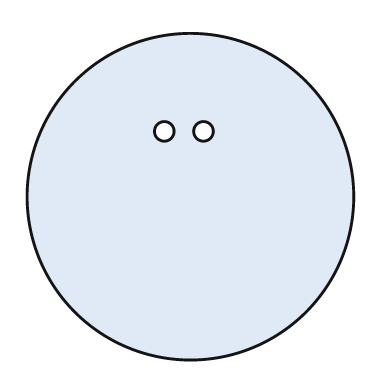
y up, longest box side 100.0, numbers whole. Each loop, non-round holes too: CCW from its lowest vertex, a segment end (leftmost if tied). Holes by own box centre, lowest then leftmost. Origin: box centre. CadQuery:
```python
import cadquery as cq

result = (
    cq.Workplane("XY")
    .moveTo(0.0, 0.0)
    .circle(50.0)
    .moveTo(-8.0, 20.0)
    .circle(3.0)
    .moveTo(4.0, 20.0)
    .circle(3.0)
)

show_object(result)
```